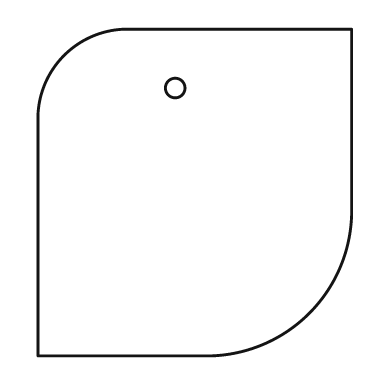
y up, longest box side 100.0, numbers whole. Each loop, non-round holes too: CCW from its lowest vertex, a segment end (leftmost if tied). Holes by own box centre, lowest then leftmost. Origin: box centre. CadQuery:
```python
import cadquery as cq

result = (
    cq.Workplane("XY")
    .moveTo(-48.0, -50.0)
    .lineTo(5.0, -50.0)
    .threePointArc((35.0, -37.0), (48.0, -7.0))
    .lineTo(48.0, 50.0)
    .lineTo(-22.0, 50.0)
    .threePointArc((-40.0, 42.0), (-48.0, 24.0))
    .close()
    .moveTo(-6.0, 32.0)
    .circle(3.0)
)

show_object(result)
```